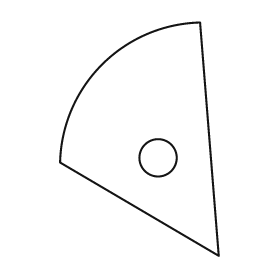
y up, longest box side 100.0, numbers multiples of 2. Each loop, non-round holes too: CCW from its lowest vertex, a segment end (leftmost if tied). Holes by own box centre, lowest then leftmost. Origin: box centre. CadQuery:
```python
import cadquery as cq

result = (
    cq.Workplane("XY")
    .moveTo(34.0, -50.0)
    .lineTo(26.0, 50.0)
    .threePointArc((-16.0, 32.0), (-34.0, -10.0))
    .close()
    .moveTo(8.0, -8.0)
    .circle(8.0)
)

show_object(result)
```